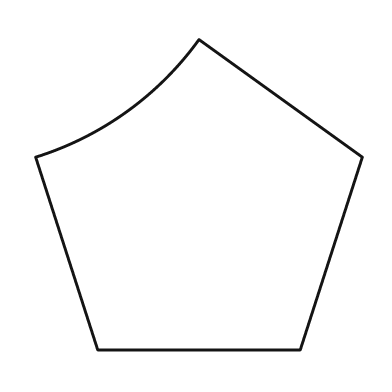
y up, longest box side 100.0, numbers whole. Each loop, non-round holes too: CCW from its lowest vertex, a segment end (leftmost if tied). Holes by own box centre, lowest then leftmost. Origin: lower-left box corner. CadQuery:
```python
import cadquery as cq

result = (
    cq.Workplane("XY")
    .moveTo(19.0, 0.0)
    .lineTo(81.0, 0.0)
    .lineTo(100.0, 59.0)
    .lineTo(50.0, 95.0)
    .threePointArc((28.0, 73.0), (0.0, 59.0))
    .close()
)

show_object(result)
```